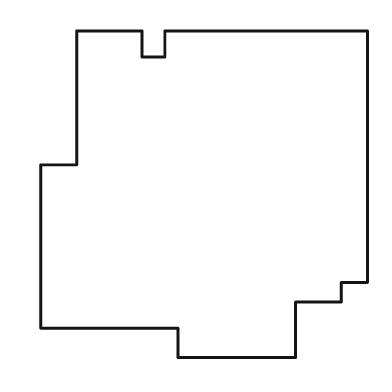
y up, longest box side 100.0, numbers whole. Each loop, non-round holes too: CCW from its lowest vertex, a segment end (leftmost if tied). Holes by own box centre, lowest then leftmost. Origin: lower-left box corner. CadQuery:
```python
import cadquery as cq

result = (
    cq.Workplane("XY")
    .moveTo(42.0, 0.0)
    .lineTo(78.0, 0.0)
    .lineTo(78.0, 17.0)
    .lineTo(92.0, 17.0)
    .lineTo(92.0, 23.0)
    .lineTo(100.0, 23.0)
    .lineTo(100.0, 100.0)
    .lineTo(38.0, 100.0)
    .lineTo(38.0, 92.0)
    .lineTo(31.0, 92.0)
    .lineTo(31.0, 100.0)
    .lineTo(11.0, 100.0)
    .lineTo(11.0, 59.0)
    .lineTo(0.0, 59.0)
    .lineTo(0.0, 9.0)
    .lineTo(42.0, 9.0)
    .close()
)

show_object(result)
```